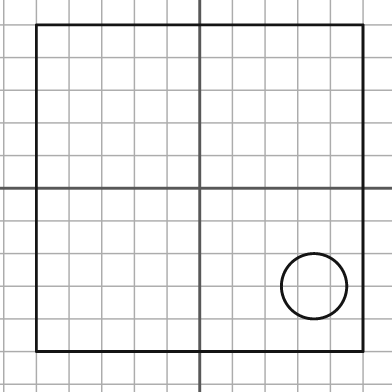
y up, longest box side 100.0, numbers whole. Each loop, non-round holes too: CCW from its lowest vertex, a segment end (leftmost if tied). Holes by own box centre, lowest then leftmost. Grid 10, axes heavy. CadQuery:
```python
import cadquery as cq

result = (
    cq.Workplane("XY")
    .moveTo(-50.0, -50.0)
    .lineTo(50.0, -50.0)
    .lineTo(50.0, 50.0)
    .lineTo(-50.0, 50.0)
    .close()
    .moveTo(35.0, -30.0)
    .circle(10.0)
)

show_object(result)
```